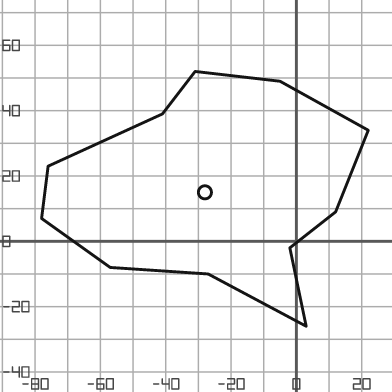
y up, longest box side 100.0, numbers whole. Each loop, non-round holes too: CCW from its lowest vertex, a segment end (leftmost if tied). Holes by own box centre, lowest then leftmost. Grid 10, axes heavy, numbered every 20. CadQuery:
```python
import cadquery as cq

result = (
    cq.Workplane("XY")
    .moveTo(3.0, -26.0)
    .lineTo(-2.0, -2.0)
    .lineTo(12.0, 9.0)
    .lineTo(22.0, 34.0)
    .lineTo(-5.0, 49.0)
    .lineTo(-31.0, 52.0)
    .lineTo(-41.0, 39.0)
    .lineTo(-76.0, 23.0)
    .lineTo(-78.0, 7.0)
    .lineTo(-57.0, -8.0)
    .lineTo(-27.0, -10.0)
    .close()
    .moveTo(-28.0, 15.0)
    .circle(2.0)
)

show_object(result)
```